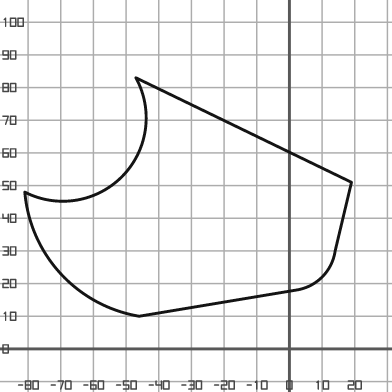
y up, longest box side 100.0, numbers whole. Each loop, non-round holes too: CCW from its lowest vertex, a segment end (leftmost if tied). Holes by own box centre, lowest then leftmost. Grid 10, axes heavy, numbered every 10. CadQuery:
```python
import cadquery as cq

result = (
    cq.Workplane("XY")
    .moveTo(-46.0, 10.0)
    .lineTo(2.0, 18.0)
    .threePointArc((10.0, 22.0), (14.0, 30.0))
    .lineTo(19.0, 51.0)
    .lineTo(-47.0, 83.0)
    .threePointArc((-51.0, 53.0), (-81.0, 48.0))
    .threePointArc((-70.0, 23.0), (-46.0, 10.0))
    .close()
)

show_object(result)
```